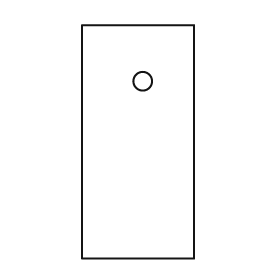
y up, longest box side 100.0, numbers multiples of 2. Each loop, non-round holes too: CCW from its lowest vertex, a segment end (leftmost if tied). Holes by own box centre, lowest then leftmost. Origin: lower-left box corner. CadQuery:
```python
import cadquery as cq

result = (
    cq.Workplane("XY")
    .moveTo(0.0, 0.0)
    .lineTo(48.0, 0.0)
    .lineTo(48.0, 100.0)
    .lineTo(0.0, 100.0)
    .close()
    .moveTo(26.0, 76.0)
    .circle(4.0)
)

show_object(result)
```